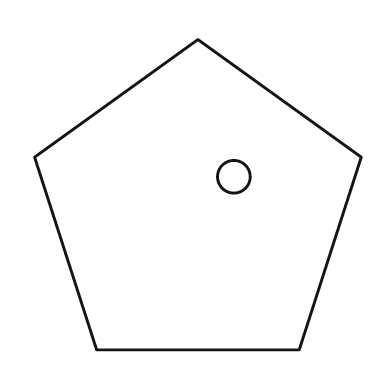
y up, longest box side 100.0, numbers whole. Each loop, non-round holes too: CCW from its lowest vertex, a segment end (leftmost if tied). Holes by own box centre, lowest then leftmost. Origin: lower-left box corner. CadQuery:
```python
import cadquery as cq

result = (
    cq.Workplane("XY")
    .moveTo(19.0, 0.0)
    .lineTo(81.0, 0.0)
    .lineTo(100.0, 59.0)
    .lineTo(50.0, 95.0)
    .lineTo(0.0, 59.0)
    .close()
    .moveTo(61.0, 53.0)
    .circle(5.0)
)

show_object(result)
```